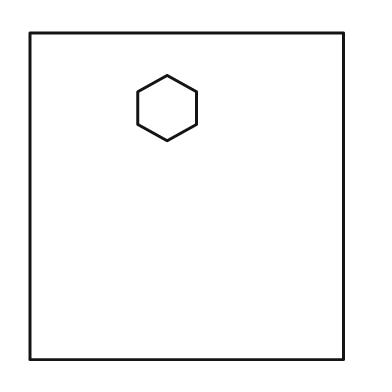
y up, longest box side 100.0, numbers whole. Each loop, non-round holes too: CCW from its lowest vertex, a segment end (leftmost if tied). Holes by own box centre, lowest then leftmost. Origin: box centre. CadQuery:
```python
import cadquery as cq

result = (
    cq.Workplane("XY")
    .moveTo(-48.0, -50.0)
    .lineTo(48.0, -50.0)
    .lineTo(48.0, 50.0)
    .lineTo(-48.0, 50.0)
    .close()
    .moveTo(-6.0, 17.0)
    .lineTo(3.0, 22.0)
    .lineTo(3.0, 32.0)
    .lineTo(-6.0, 37.0)
    .lineTo(-15.0, 32.0)
    .lineTo(-15.0, 22.0)
    .close()
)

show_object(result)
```